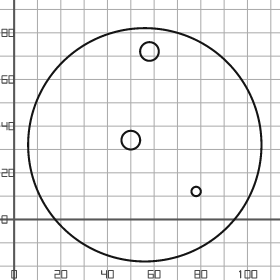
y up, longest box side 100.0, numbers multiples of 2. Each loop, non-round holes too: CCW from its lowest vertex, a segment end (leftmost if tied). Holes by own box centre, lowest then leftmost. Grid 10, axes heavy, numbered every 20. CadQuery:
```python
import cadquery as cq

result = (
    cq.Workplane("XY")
    .moveTo(56.0, 32.0)
    .circle(50.0)
    .moveTo(78.0, 12.0)
    .circle(2.0)
    .moveTo(50.0, 34.0)
    .circle(4.0)
    .moveTo(58.0, 72.0)
    .circle(4.0)
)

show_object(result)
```